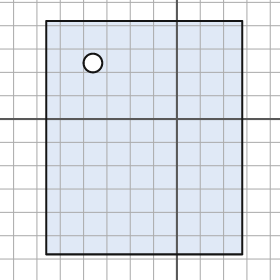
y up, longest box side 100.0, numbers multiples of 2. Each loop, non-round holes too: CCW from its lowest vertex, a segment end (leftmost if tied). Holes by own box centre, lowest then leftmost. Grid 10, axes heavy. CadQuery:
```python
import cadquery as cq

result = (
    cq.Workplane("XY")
    .moveTo(-56.0, -58.0)
    .lineTo(28.0, -58.0)
    .lineTo(28.0, 42.0)
    .lineTo(-56.0, 42.0)
    .close()
    .moveTo(-36.0, 24.0)
    .circle(4.0)
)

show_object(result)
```